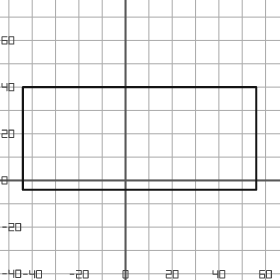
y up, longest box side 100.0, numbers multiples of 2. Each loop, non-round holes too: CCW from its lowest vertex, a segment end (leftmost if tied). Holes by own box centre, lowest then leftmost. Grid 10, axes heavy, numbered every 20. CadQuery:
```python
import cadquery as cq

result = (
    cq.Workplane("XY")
    .moveTo(-44.0, -4.0)
    .lineTo(56.0, -4.0)
    .lineTo(56.0, 40.0)
    .lineTo(-44.0, 40.0)
    .close()
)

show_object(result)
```